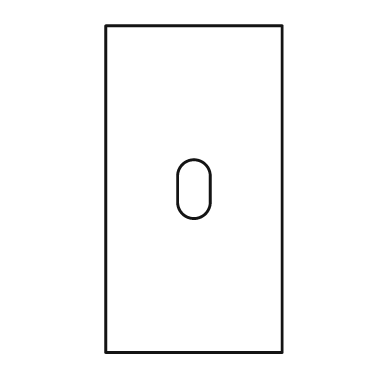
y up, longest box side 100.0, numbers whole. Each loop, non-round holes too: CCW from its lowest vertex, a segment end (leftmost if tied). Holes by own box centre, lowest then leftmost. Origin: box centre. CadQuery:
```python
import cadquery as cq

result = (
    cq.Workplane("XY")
    .moveTo(-27.0, -50.0)
    .lineTo(27.0, -50.0)
    .lineTo(27.0, 50.0)
    .lineTo(-27.0, 50.0)
    .close()
    .moveTo(-5.0, -4.0)
    .threePointArc((0.0, -9.0), (5.0, -4.0))
    .lineTo(5.0, 4.0)
    .threePointArc((0.0, 9.0), (-5.0, 4.0))
    .close()
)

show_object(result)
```